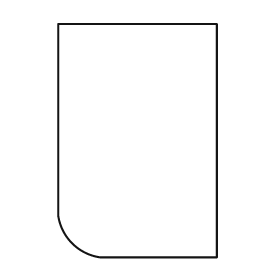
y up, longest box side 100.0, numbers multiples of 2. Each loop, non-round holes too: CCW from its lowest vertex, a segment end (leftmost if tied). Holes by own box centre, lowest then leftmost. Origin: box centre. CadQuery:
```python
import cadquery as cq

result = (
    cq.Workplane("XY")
    .moveTo(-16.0, -50.0)
    .lineTo(34.0, -50.0)
    .lineTo(34.0, 50.0)
    .lineTo(-34.0, 50.0)
    .lineTo(-34.0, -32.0)
    .threePointArc((-28.0, -44.0), (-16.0, -50.0))
    .close()
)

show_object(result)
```